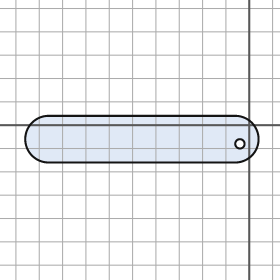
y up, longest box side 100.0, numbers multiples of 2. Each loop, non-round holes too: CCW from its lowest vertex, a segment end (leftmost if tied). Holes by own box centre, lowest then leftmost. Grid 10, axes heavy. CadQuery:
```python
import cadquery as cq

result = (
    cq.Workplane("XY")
    .moveTo(-86.0, -16.0)
    .lineTo(-6.0, -16.0)
    .threePointArc((4.0, -6.0), (-6.0, 4.0))
    .lineTo(-86.0, 4.0)
    .threePointArc((-96.0, -6.0), (-86.0, -16.0))
    .close()
    .moveTo(-4.0, -8.0)
    .circle(2.0)
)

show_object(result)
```